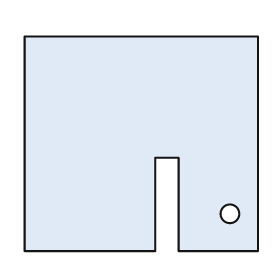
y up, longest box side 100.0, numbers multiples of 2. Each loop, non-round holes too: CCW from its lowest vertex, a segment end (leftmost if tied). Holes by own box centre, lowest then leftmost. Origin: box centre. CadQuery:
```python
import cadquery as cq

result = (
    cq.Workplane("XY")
    .moveTo(-50.0, -46.0)
    .lineTo(6.0, -46.0)
    .lineTo(6.0, -6.0)
    .lineTo(16.0, -6.0)
    .lineTo(16.0, -46.0)
    .lineTo(50.0, -46.0)
    .lineTo(50.0, 46.0)
    .lineTo(-50.0, 46.0)
    .close()
    .moveTo(38.0, -30.0)
    .circle(4.0)
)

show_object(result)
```